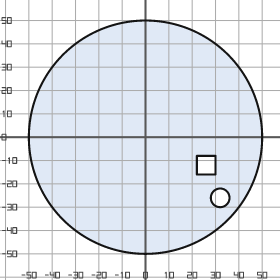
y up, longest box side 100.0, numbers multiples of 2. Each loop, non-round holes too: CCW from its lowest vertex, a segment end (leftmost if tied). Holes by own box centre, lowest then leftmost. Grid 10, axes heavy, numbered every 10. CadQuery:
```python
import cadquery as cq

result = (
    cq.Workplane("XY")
    .moveTo(0.0, 0.0)
    .circle(50.0)
    .moveTo(32.0, -26.0)
    .circle(4.0)
    .moveTo(22.0, -16.0)
    .lineTo(30.0, -16.0)
    .lineTo(30.0, -8.0)
    .lineTo(22.0, -8.0)
    .close()
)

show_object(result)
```